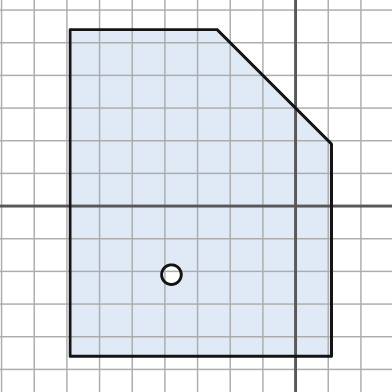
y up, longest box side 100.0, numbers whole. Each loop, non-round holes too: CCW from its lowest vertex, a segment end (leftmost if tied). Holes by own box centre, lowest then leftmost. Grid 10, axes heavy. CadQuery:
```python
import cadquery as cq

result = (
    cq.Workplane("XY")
    .moveTo(-69.0, -46.0)
    .lineTo(11.0, -46.0)
    .lineTo(11.0, 19.0)
    .lineTo(-24.0, 54.0)
    .lineTo(-69.0, 54.0)
    .close()
    .moveTo(-38.0, -21.0)
    .circle(3.0)
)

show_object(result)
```